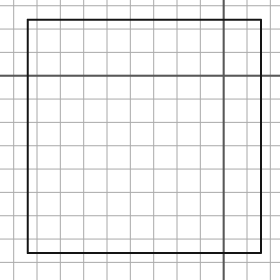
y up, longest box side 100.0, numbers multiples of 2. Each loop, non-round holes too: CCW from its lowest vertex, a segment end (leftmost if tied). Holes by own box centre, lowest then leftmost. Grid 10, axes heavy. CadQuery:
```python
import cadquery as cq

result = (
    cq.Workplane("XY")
    .moveTo(-84.0, -76.0)
    .lineTo(16.0, -76.0)
    .lineTo(16.0, 24.0)
    .lineTo(-84.0, 24.0)
    .close()
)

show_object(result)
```